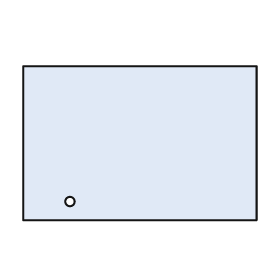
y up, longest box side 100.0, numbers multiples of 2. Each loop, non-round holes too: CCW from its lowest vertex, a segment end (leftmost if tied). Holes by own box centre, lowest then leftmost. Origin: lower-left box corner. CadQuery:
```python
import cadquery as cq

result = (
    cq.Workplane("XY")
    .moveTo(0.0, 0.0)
    .lineTo(100.0, 0.0)
    .lineTo(100.0, 66.0)
    .lineTo(0.0, 66.0)
    .close()
    .moveTo(20.0, 8.0)
    .circle(2.0)
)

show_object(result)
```